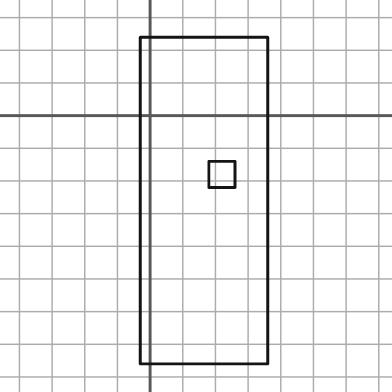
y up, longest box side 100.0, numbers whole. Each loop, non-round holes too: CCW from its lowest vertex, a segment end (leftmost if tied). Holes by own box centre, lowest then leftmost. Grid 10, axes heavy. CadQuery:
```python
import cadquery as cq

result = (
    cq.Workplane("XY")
    .moveTo(-3.0, -76.0)
    .lineTo(36.0, -76.0)
    .lineTo(36.0, 24.0)
    .lineTo(-3.0, 24.0)
    .close()
    .moveTo(18.0, -22.0)
    .lineTo(26.0, -22.0)
    .lineTo(26.0, -14.0)
    .lineTo(18.0, -14.0)
    .close()
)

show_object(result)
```